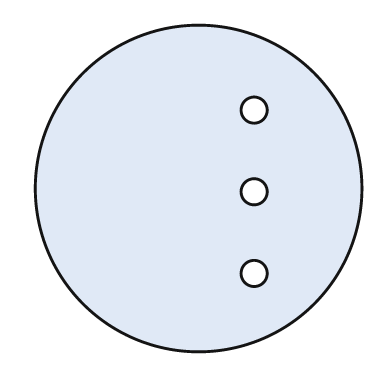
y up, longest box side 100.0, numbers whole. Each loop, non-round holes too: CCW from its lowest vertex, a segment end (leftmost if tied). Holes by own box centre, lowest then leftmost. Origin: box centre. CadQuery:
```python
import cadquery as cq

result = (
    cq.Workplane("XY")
    .moveTo(0.0, 0.0)
    .circle(50.0)
    .moveTo(17.0, -26.0)
    .circle(4.0)
    .moveTo(17.0, -1.0)
    .circle(4.0)
    .moveTo(17.0, 24.0)
    .circle(4.0)
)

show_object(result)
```